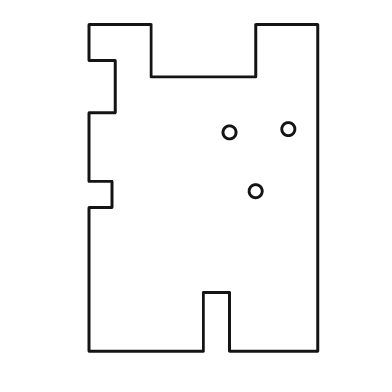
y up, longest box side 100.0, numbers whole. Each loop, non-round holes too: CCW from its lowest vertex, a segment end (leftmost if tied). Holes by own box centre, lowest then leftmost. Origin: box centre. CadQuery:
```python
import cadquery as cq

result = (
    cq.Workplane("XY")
    .moveTo(-35.0, -50.0)
    .lineTo(0.0, -50.0)
    .lineTo(0.0, -32.0)
    .lineTo(8.0, -32.0)
    .lineTo(8.0, -50.0)
    .lineTo(35.0, -50.0)
    .lineTo(35.0, 50.0)
    .lineTo(16.0, 50.0)
    .lineTo(16.0, 34.0)
    .lineTo(-16.0, 34.0)
    .lineTo(-16.0, 50.0)
    .lineTo(-35.0, 50.0)
    .lineTo(-35.0, 39.0)
    .lineTo(-27.0, 39.0)
    .lineTo(-27.0, 23.0)
    .lineTo(-35.0, 23.0)
    .lineTo(-35.0, 2.0)
    .lineTo(-28.0, 2.0)
    .lineTo(-28.0, -6.0)
    .lineTo(-35.0, -6.0)
    .close()
    .moveTo(16.0, -1.0)
    .circle(2.0)
    .moveTo(8.0, 17.0)
    .circle(2.0)
    .moveTo(26.0, 18.0)
    .circle(2.0)
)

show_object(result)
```